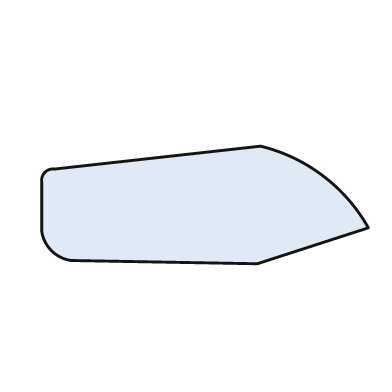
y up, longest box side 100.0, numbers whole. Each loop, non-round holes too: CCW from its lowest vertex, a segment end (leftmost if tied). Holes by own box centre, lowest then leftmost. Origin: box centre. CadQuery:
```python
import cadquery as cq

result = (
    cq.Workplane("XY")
    .moveTo(16.0, -18.0)
    .lineTo(50.0, -7.0)
    .threePointArc((36.0, 9.0), (17.0, 18.0))
    .lineTo(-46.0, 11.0)
    .threePointArc((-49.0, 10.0), (-50.0, 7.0))
    .lineTo(-50.0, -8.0)
    .threePointArc((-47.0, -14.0), (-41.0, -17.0))
    .close()
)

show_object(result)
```